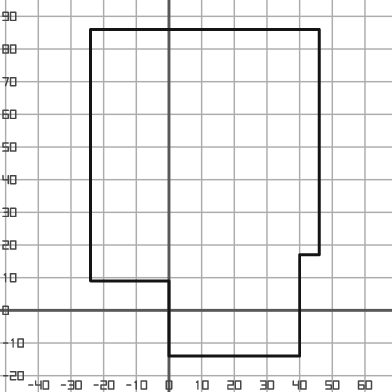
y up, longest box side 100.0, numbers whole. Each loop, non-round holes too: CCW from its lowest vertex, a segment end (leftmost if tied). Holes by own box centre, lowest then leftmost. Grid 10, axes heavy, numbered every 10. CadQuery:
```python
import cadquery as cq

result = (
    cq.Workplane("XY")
    .moveTo(0.0, -14.0)
    .lineTo(40.0, -14.0)
    .lineTo(40.0, 17.0)
    .lineTo(46.0, 17.0)
    .lineTo(46.0, 86.0)
    .lineTo(-24.0, 86.0)
    .lineTo(-24.0, 9.0)
    .lineTo(0.0, 9.0)
    .close()
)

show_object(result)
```